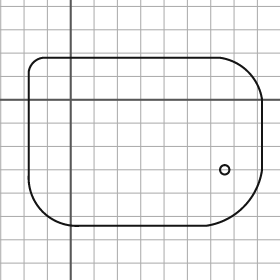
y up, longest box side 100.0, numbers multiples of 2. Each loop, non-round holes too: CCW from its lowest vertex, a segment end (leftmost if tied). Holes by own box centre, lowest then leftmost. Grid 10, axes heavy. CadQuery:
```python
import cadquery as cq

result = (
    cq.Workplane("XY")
    .moveTo(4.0, -54.0)
    .lineTo(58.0, -54.0)
    .threePointArc((74.0, -46.0), (82.0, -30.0))
    .lineTo(82.0, 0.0)
    .threePointArc((76.0, 12.0), (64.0, 18.0))
    .lineTo(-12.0, 18.0)
    .threePointArc((-16.0, 16.0), (-18.0, 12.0))
    .lineTo(-18.0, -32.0)
    .threePointArc((-12.0, -48.0), (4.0, -54.0))
    .close()
    .moveTo(66.0, -30.0)
    .circle(2.0)
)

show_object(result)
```